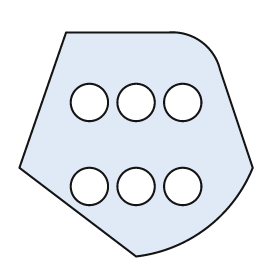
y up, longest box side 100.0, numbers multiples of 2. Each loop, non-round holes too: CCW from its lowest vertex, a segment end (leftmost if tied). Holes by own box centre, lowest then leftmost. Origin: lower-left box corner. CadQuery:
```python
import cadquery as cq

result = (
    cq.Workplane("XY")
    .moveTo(50.0, 0.0)
    .threePointArc((80.0, 12.0), (100.0, 38.0))
    .lineTo(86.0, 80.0)
    .threePointArc((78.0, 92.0), (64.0, 96.0))
    .lineTo(20.0, 96.0)
    .lineTo(0.0, 38.0)
    .close()
    .moveTo(30.0, 30.0)
    .circle(8.0)
    .moveTo(50.0, 30.0)
    .circle(8.0)
    .moveTo(70.0, 30.0)
    .circle(8.0)
    .moveTo(30.0, 66.0)
    .circle(8.0)
    .moveTo(50.0, 66.0)
    .circle(8.0)
    .moveTo(70.0, 66.0)
    .circle(8.0)
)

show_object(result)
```